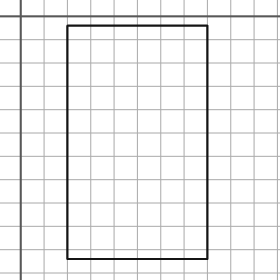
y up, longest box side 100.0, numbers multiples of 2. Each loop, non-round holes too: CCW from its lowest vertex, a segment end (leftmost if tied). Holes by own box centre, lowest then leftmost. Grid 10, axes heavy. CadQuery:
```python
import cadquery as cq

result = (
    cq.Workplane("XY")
    .moveTo(20.0, -104.0)
    .lineTo(80.0, -104.0)
    .lineTo(80.0, -4.0)
    .lineTo(20.0, -4.0)
    .close()
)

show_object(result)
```